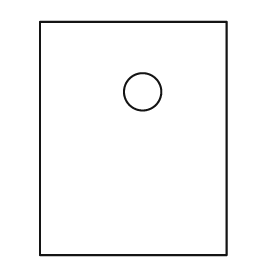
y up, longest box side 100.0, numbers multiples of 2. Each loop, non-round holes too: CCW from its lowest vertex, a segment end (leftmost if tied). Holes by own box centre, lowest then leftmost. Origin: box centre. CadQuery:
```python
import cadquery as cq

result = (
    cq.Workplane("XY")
    .moveTo(-40.0, -50.0)
    .lineTo(40.0, -50.0)
    .lineTo(40.0, 50.0)
    .lineTo(-40.0, 50.0)
    .close()
    .moveTo(4.0, 20.0)
    .circle(8.0)
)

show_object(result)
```